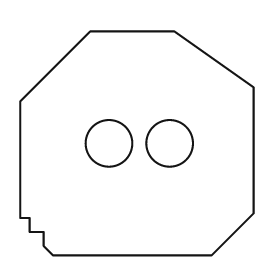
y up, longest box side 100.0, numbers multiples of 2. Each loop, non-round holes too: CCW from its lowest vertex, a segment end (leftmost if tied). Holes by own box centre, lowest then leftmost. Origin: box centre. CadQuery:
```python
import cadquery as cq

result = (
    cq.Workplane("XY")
    .moveTo(-36.0, -48.0)
    .lineTo(32.0, -48.0)
    .lineTo(50.0, -30.0)
    .lineTo(50.0, 24.0)
    .lineTo(16.0, 48.0)
    .lineTo(-20.0, 48.0)
    .lineTo(-50.0, 18.0)
    .lineTo(-50.0, -32.0)
    .lineTo(-46.0, -32.0)
    .lineTo(-46.0, -38.0)
    .lineTo(-40.0, -38.0)
    .lineTo(-40.0, -44.0)
    .close()
    .moveTo(-12.0, 0.0)
    .circle(10.0)
    .moveTo(14.0, 0.0)
    .circle(10.0)
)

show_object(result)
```